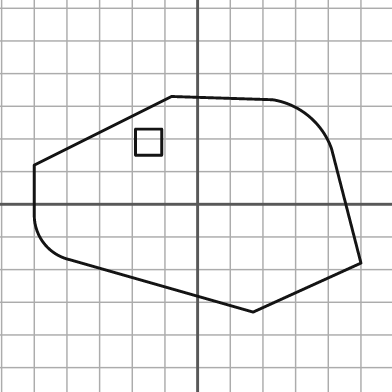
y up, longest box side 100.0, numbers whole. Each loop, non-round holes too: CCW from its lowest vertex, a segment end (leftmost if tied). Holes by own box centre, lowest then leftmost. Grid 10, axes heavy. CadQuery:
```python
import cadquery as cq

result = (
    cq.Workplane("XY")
    .moveTo(17.0, -33.0)
    .lineTo(50.0, -18.0)
    .lineTo(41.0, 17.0)
    .threePointArc((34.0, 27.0), (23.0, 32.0))
    .lineTo(-8.0, 33.0)
    .lineTo(-50.0, 12.0)
    .lineTo(-50.0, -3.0)
    .threePointArc((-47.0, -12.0), (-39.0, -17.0))
    .close()
    .moveTo(-19.0, 15.0)
    .lineTo(-11.0, 15.0)
    .lineTo(-11.0, 23.0)
    .lineTo(-19.0, 23.0)
    .close()
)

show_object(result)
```